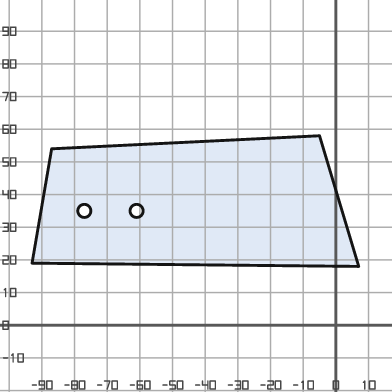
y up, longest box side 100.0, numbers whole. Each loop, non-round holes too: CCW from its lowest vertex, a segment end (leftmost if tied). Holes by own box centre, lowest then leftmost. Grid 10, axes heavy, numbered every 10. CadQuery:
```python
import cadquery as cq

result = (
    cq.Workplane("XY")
    .moveTo(7.0, 18.0)
    .lineTo(-5.0, 58.0)
    .lineTo(-87.0, 54.0)
    .lineTo(-93.0, 19.0)
    .close()
    .moveTo(-77.0, 35.0)
    .circle(2.0)
    .moveTo(-61.0, 35.0)
    .circle(2.0)
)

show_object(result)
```